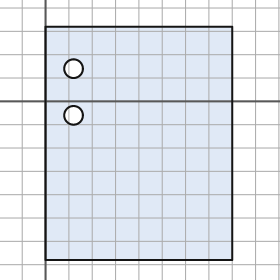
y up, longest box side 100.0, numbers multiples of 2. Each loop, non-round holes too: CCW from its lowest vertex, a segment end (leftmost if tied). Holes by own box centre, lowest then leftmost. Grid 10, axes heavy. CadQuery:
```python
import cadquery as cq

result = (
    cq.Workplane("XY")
    .moveTo(0.0, -68.0)
    .lineTo(80.0, -68.0)
    .lineTo(80.0, 32.0)
    .lineTo(0.0, 32.0)
    .close()
    .moveTo(12.0, -6.0)
    .circle(4.0)
    .moveTo(12.0, 14.0)
    .circle(4.0)
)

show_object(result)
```